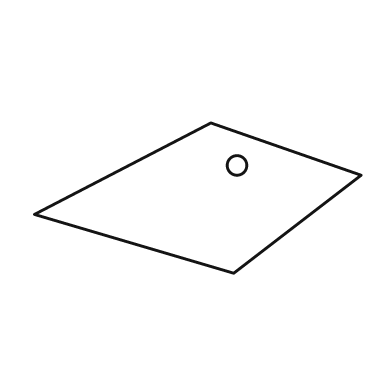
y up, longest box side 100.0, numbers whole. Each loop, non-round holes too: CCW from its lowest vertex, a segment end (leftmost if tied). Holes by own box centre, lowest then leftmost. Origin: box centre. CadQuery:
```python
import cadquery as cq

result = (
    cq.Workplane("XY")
    .moveTo(11.0, -23.0)
    .lineTo(50.0, 7.0)
    .lineTo(4.0, 23.0)
    .lineTo(-50.0, -5.0)
    .close()
    .moveTo(12.0, 10.0)
    .circle(3.0)
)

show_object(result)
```